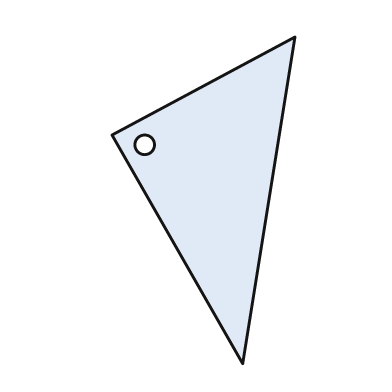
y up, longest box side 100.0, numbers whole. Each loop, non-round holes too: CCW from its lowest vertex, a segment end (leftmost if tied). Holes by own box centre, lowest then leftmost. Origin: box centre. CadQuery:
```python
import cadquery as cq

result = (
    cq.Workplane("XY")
    .moveTo(12.0, -50.0)
    .lineTo(28.0, 50.0)
    .lineTo(-28.0, 20.0)
    .close()
    .moveTo(-18.0, 17.0)
    .circle(3.0)
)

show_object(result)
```